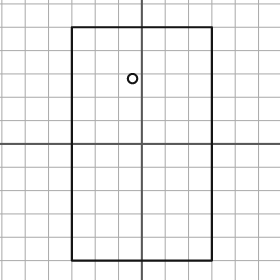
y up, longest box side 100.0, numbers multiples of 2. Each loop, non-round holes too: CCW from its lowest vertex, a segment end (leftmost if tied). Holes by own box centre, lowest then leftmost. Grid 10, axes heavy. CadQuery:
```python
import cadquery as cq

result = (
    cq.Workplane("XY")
    .moveTo(-30.0, -50.0)
    .lineTo(30.0, -50.0)
    .lineTo(30.0, 50.0)
    .lineTo(-30.0, 50.0)
    .close()
    .moveTo(-4.0, 28.0)
    .circle(2.0)
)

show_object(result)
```